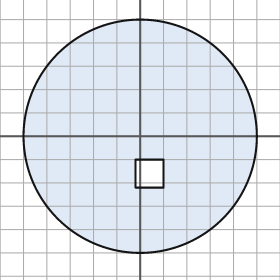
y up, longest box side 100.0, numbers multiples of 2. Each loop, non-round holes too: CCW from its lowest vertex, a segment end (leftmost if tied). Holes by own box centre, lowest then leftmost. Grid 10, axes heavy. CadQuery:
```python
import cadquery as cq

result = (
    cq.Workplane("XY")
    .moveTo(0.0, 0.0)
    .circle(50.0)
    .moveTo(-2.0, -22.0)
    .lineTo(10.0, -22.0)
    .lineTo(10.0, -10.0)
    .lineTo(-2.0, -10.0)
    .close()
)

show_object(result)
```